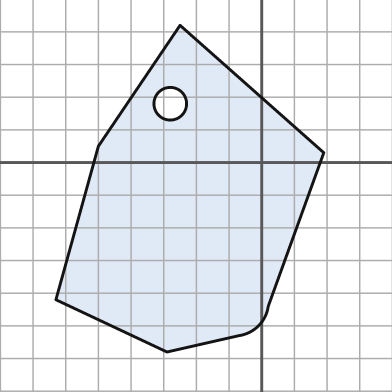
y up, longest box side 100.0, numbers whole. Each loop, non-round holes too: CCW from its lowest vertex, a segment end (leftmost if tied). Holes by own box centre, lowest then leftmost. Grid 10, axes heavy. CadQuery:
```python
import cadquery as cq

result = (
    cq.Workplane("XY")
    .moveTo(-29.0, -58.0)
    .lineTo(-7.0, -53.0)
    .threePointArc((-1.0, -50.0), (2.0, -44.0))
    .lineTo(19.0, 3.0)
    .lineTo(-25.0, 42.0)
    .lineTo(-50.0, 5.0)
    .lineTo(-63.0, -42.0)
    .close()
    .moveTo(-28.0, 18.0)
    .circle(5.0)
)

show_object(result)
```